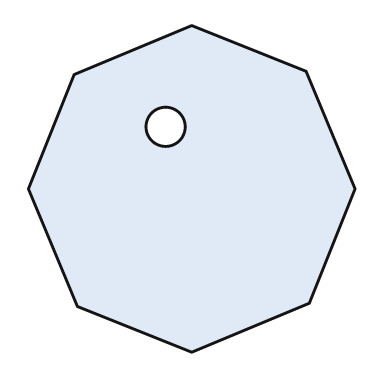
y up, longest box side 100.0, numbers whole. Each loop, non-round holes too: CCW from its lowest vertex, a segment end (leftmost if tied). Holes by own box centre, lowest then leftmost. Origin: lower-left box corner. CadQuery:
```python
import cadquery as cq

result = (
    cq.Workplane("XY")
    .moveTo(50.0, 0.0)
    .lineTo(86.0, 15.0)
    .lineTo(100.0, 50.0)
    .lineTo(85.0, 86.0)
    .lineTo(50.0, 100.0)
    .lineTo(14.0, 85.0)
    .lineTo(0.0, 50.0)
    .lineTo(15.0, 14.0)
    .close()
    .moveTo(42.0, 69.0)
    .circle(6.0)
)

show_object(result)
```